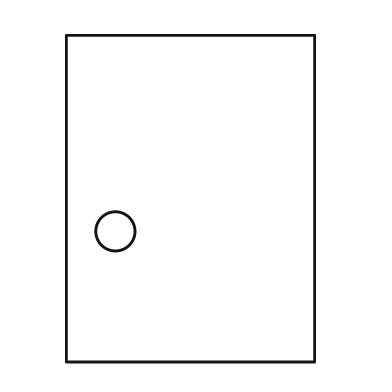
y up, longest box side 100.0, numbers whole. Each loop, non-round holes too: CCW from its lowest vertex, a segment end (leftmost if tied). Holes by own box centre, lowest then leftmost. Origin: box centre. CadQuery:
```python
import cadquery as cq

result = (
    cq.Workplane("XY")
    .moveTo(-38.0, -50.0)
    .lineTo(38.0, -50.0)
    .lineTo(38.0, 50.0)
    .lineTo(-38.0, 50.0)
    .close()
    .moveTo(-23.0, -10.0)
    .circle(6.0)
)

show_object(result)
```